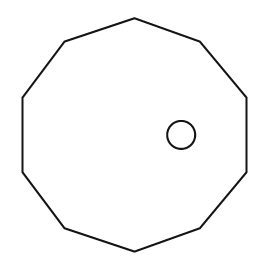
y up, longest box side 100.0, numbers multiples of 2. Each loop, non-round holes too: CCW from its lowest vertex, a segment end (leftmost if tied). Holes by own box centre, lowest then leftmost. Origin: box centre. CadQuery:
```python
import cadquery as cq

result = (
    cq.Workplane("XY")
    .moveTo(0.0, -50.0)
    .lineTo(28.0, -40.0)
    .lineTo(48.0, -16.0)
    .lineTo(48.0, 16.0)
    .lineTo(28.0, 40.0)
    .lineTo(0.0, 50.0)
    .lineTo(-30.0, 40.0)
    .lineTo(-48.0, 16.0)
    .lineTo(-48.0, -16.0)
    .lineTo(-30.0, -40.0)
    .close()
    .moveTo(20.0, 0.0)
    .circle(6.0)
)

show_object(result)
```